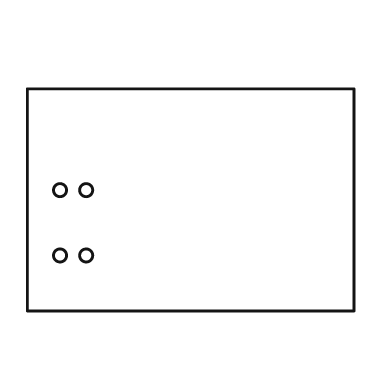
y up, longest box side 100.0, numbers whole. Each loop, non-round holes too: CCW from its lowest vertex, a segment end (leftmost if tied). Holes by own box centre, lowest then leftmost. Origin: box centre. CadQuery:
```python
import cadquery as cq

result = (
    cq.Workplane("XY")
    .moveTo(-50.0, -34.0)
    .lineTo(50.0, -34.0)
    .lineTo(50.0, 34.0)
    .lineTo(-50.0, 34.0)
    .close()
    .moveTo(-40.0, -17.0)
    .circle(2.0)
    .moveTo(-32.0, -17.0)
    .circle(2.0)
    .moveTo(-40.0, 3.0)
    .circle(2.0)
    .moveTo(-32.0, 3.0)
    .circle(2.0)
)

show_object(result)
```